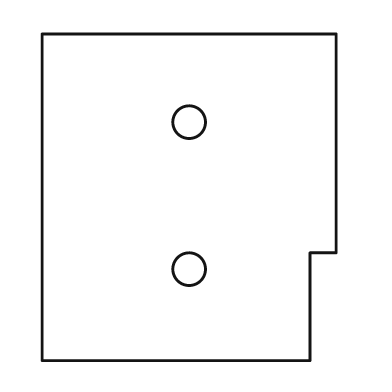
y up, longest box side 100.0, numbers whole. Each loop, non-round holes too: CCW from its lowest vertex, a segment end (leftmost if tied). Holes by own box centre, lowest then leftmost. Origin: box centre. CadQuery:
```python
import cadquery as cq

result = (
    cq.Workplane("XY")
    .moveTo(-45.0, -50.0)
    .lineTo(37.0, -50.0)
    .lineTo(37.0, -17.0)
    .lineTo(45.0, -17.0)
    .lineTo(45.0, 50.0)
    .lineTo(-45.0, 50.0)
    .close()
    .moveTo(0.0, -22.0)
    .circle(5.0)
    .moveTo(0.0, 23.0)
    .circle(5.0)
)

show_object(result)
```